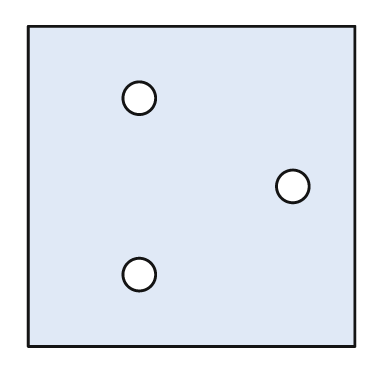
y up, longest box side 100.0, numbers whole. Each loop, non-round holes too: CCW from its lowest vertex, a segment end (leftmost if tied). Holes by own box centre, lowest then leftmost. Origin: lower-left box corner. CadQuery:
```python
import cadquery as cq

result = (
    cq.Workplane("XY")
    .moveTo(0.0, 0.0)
    .lineTo(100.0, 0.0)
    .lineTo(100.0, 98.0)
    .lineTo(0.0, 98.0)
    .close()
    .moveTo(34.0, 22.0)
    .circle(5.0)
    .moveTo(81.0, 49.0)
    .circle(5.0)
    .moveTo(34.0, 76.0)
    .circle(5.0)
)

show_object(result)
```